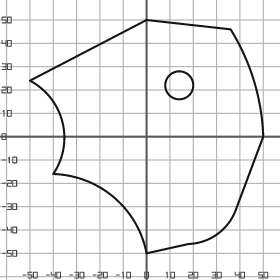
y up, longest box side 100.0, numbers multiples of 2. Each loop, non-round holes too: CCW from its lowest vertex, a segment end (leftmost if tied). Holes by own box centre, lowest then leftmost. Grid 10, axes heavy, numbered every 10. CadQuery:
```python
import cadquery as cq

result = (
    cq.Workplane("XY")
    .moveTo(0.0, -50.0)
    .lineTo(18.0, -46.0)
    .threePointArc((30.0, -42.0), (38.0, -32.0))
    .lineTo(50.0, 0.0)
    .threePointArc((46.0, 24.0), (36.0, 46.0))
    .lineTo(0.0, 50.0)
    .lineTo(-50.0, 24.0)
    .threePointArc((-36.0, 6.0), (-40.0, -16.0))
    .threePointArc((-14.0, -26.0), (0.0, -50.0))
    .close()
    .moveTo(14.0, 22.0)
    .circle(6.0)
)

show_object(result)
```